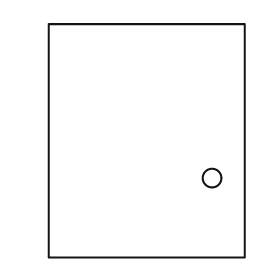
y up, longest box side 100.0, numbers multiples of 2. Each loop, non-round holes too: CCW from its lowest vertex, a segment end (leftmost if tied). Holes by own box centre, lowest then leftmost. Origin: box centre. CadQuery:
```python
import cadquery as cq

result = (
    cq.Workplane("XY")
    .moveTo(-42.0, -50.0)
    .lineTo(42.0, -50.0)
    .lineTo(42.0, 50.0)
    .lineTo(-42.0, 50.0)
    .close()
    .moveTo(28.0, -16.0)
    .circle(4.0)
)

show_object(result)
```